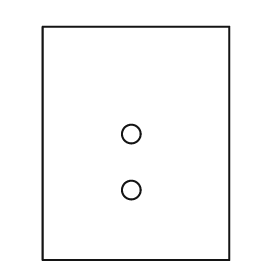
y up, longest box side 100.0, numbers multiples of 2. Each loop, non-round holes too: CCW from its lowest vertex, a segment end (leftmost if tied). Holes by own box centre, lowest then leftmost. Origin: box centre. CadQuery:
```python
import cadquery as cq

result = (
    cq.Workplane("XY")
    .moveTo(-40.0, -50.0)
    .lineTo(40.0, -50.0)
    .lineTo(40.0, 50.0)
    .lineTo(-40.0, 50.0)
    .close()
    .moveTo(-2.0, -20.0)
    .circle(4.0)
    .moveTo(-2.0, 4.0)
    .circle(4.0)
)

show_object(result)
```